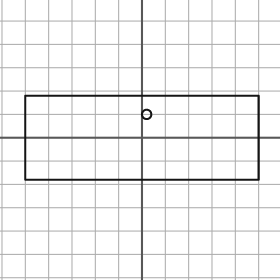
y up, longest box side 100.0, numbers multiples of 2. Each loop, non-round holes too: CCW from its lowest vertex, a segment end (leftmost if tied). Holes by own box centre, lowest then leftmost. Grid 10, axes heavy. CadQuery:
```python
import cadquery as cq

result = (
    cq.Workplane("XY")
    .moveTo(-50.0, -18.0)
    .lineTo(50.0, -18.0)
    .lineTo(50.0, 18.0)
    .lineTo(-50.0, 18.0)
    .close()
    .moveTo(2.0, 10.0)
    .circle(2.0)
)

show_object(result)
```